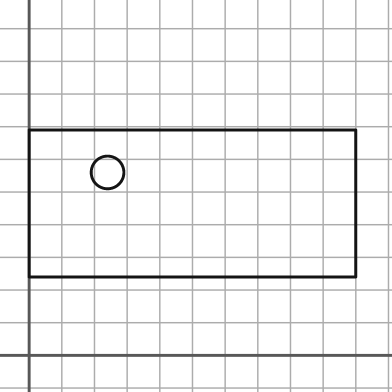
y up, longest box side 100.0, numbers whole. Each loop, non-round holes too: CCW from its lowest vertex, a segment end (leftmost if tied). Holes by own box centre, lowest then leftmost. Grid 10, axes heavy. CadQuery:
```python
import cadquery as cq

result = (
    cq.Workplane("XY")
    .moveTo(0.0, 24.0)
    .lineTo(100.0, 24.0)
    .lineTo(100.0, 69.0)
    .lineTo(0.0, 69.0)
    .close()
    .moveTo(24.0, 56.0)
    .circle(5.0)
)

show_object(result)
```